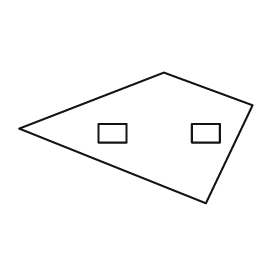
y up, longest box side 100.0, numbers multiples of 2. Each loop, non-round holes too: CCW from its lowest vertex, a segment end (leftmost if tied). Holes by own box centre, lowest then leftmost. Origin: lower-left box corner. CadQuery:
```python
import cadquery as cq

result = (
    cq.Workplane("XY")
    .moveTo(80.0, 0.0)
    .lineTo(100.0, 42.0)
    .lineTo(62.0, 56.0)
    .lineTo(0.0, 32.0)
    .close()
    .moveTo(34.0, 26.0)
    .lineTo(46.0, 26.0)
    .lineTo(46.0, 34.0)
    .lineTo(34.0, 34.0)
    .close()
    .moveTo(74.0, 26.0)
    .lineTo(86.0, 26.0)
    .lineTo(86.0, 34.0)
    .lineTo(74.0, 34.0)
    .close()
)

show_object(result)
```